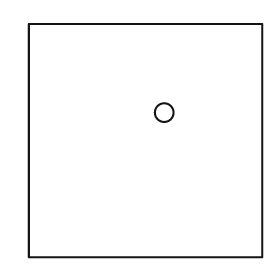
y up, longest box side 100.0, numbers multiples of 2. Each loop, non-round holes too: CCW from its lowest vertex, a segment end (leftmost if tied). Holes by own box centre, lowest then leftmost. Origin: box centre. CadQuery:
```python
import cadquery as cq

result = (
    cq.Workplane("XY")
    .moveTo(-50.0, -50.0)
    .lineTo(50.0, -50.0)
    .lineTo(50.0, 50.0)
    .lineTo(-50.0, 50.0)
    .close()
    .moveTo(8.0, 12.0)
    .circle(4.0)
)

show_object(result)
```